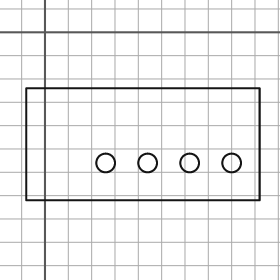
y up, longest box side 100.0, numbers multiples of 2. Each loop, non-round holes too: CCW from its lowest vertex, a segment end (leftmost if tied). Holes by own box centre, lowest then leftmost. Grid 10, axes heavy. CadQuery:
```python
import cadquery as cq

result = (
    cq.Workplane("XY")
    .moveTo(-8.0, -72.0)
    .lineTo(92.0, -72.0)
    .lineTo(92.0, -24.0)
    .lineTo(-8.0, -24.0)
    .close()
    .moveTo(26.0, -56.0)
    .circle(4.0)
    .moveTo(44.0, -56.0)
    .circle(4.0)
    .moveTo(62.0, -56.0)
    .circle(4.0)
    .moveTo(80.0, -56.0)
    .circle(4.0)
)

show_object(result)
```